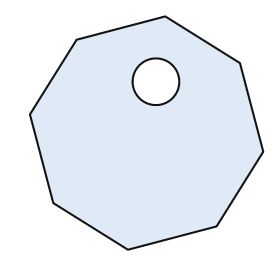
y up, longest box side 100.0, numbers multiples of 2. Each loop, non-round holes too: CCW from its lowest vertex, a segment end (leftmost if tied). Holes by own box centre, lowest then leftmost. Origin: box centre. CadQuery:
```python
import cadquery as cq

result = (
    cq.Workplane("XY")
    .moveTo(-8.0, -50.0)
    .lineTo(30.0, -40.0)
    .lineTo(50.0, -8.0)
    .lineTo(40.0, 30.0)
    .lineTo(8.0, 50.0)
    .lineTo(-30.0, 40.0)
    .lineTo(-50.0, 8.0)
    .lineTo(-40.0, -30.0)
    .close()
    .moveTo(4.0, 22.0)
    .circle(10.0)
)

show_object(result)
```